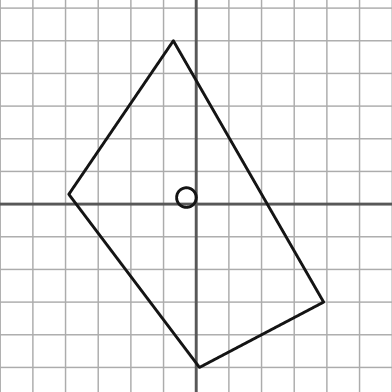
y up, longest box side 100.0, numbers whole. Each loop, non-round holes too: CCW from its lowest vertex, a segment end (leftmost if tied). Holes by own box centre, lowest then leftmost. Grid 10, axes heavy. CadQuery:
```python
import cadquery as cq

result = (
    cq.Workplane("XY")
    .moveTo(1.0, -50.0)
    .lineTo(39.0, -30.0)
    .lineTo(-7.0, 50.0)
    .lineTo(-39.0, 3.0)
    .close()
    .moveTo(-3.0, 2.0)
    .circle(3.0)
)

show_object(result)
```